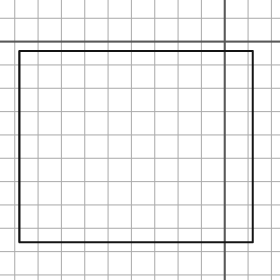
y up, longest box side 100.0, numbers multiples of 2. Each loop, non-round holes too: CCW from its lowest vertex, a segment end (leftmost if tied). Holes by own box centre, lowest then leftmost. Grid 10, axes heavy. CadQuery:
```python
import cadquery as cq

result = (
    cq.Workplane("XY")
    .moveTo(-88.0, -86.0)
    .lineTo(12.0, -86.0)
    .lineTo(12.0, -4.0)
    .lineTo(-88.0, -4.0)
    .close()
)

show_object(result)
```